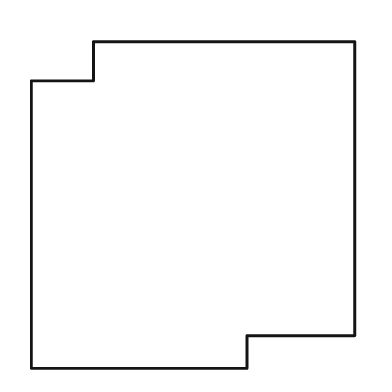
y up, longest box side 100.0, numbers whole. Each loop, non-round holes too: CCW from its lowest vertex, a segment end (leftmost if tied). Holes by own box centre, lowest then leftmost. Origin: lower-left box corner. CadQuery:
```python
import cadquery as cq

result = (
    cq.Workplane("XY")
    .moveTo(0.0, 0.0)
    .lineTo(66.0, 0.0)
    .lineTo(66.0, 10.0)
    .lineTo(99.0, 10.0)
    .lineTo(99.0, 100.0)
    .lineTo(19.0, 100.0)
    .lineTo(19.0, 88.0)
    .lineTo(0.0, 88.0)
    .close()
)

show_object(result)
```